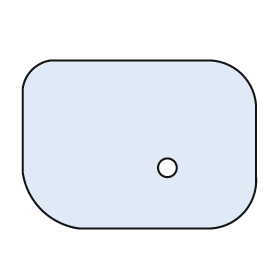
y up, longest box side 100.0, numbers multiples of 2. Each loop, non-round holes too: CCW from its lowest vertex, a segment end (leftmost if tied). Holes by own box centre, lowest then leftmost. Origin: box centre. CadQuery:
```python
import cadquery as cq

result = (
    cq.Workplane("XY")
    .moveTo(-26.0, -36.0)
    .lineTo(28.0, -36.0)
    .threePointArc((44.0, -30.0), (50.0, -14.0))
    .lineTo(50.0, 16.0)
    .threePointArc((44.0, 30.0), (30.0, 36.0))
    .lineTo(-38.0, 36.0)
    .threePointArc((-46.0, 32.0), (-50.0, 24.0))
    .lineTo(-50.0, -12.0)
    .threePointArc((-42.0, -28.0), (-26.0, -36.0))
    .close()
    .moveTo(12.0, -10.0)
    .circle(4.0)
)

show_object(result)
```